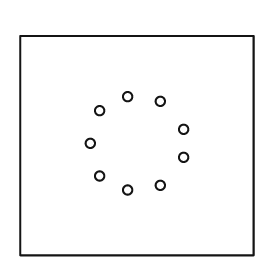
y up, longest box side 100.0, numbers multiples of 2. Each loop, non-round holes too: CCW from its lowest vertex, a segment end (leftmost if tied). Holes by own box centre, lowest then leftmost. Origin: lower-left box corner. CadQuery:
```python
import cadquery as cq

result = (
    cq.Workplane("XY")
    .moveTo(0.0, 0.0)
    .lineTo(100.0, 0.0)
    .lineTo(100.0, 94.0)
    .lineTo(0.0, 94.0)
    .close()
    .moveTo(46.0, 28.0)
    .circle(2.0)
    .moveTo(60.0, 30.0)
    .circle(2.0)
    .moveTo(34.0, 34.0)
    .circle(2.0)
    .moveTo(70.0, 42.0)
    .circle(2.0)
    .moveTo(30.0, 48.0)
    .circle(2.0)
    .moveTo(70.0, 54.0)
    .circle(2.0)
    .moveTo(34.0, 62.0)
    .circle(2.0)
    .moveTo(60.0, 66.0)
    .circle(2.0)
    .moveTo(46.0, 68.0)
    .circle(2.0)
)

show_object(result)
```